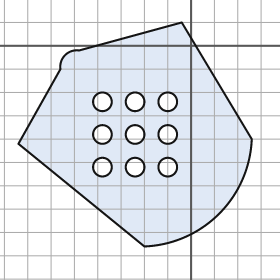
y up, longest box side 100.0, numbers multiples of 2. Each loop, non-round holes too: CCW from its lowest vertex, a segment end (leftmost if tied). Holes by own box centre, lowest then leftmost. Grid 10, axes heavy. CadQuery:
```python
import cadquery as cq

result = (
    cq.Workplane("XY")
    .moveTo(-20.0, -86.0)
    .threePointArc((12.0, -72.0), (26.0, -40.0))
    .lineTo(-4.0, 10.0)
    .lineTo(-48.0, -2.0)
    .threePointArc((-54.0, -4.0), (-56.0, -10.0))
    .lineTo(-74.0, -42.0)
    .close()
    .moveTo(-38.0, -52.0)
    .circle(4.0)
    .moveTo(-24.0, -52.0)
    .circle(4.0)
    .moveTo(-10.0, -52.0)
    .circle(4.0)
    .moveTo(-38.0, -38.0)
    .circle(4.0)
    .moveTo(-24.0, -38.0)
    .circle(4.0)
    .moveTo(-10.0, -38.0)
    .circle(4.0)
    .moveTo(-38.0, -24.0)
    .circle(4.0)
    .moveTo(-24.0, -24.0)
    .circle(4.0)
    .moveTo(-10.0, -24.0)
    .circle(4.0)
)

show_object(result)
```